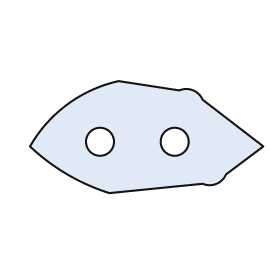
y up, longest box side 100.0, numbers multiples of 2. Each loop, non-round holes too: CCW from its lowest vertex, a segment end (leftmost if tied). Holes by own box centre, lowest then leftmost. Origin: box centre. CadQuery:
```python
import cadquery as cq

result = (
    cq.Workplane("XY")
    .moveTo(-16.0, -24.0)
    .lineTo(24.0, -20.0)
    .threePointArc((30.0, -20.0), (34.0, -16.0))
    .lineTo(50.0, -4.0)
    .lineTo(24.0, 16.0)
    .threePointArc((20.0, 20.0), (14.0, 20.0))
    .lineTo(-12.0, 24.0)
    .threePointArc((-34.0, 14.0), (-50.0, -4.0))
    .threePointArc((-34.0, -16.0), (-16.0, -24.0))
    .close()
    .moveTo(-20.0, -2.0)
    .circle(6.0)
    .moveTo(12.0, -2.0)
    .circle(6.0)
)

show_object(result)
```